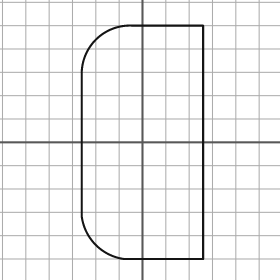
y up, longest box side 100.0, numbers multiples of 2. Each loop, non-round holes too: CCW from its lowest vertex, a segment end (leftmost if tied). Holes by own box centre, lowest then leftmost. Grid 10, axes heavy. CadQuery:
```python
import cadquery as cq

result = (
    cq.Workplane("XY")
    .moveTo(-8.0, -50.0)
    .lineTo(26.0, -50.0)
    .lineTo(26.0, 50.0)
    .lineTo(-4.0, 50.0)
    .threePointArc((-20.0, 44.0), (-26.0, 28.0))
    .lineTo(-26.0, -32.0)
    .threePointArc((-20.0, -44.0), (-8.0, -50.0))
    .close()
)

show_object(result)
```